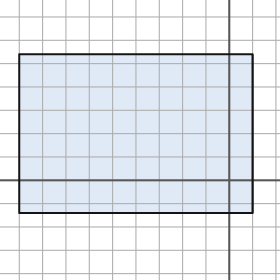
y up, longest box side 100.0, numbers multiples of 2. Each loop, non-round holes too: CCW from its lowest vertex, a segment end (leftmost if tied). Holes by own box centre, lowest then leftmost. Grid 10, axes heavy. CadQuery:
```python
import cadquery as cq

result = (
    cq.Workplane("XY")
    .moveTo(-90.0, -14.0)
    .lineTo(10.0, -14.0)
    .lineTo(10.0, 54.0)
    .lineTo(-90.0, 54.0)
    .close()
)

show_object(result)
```